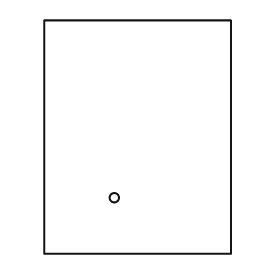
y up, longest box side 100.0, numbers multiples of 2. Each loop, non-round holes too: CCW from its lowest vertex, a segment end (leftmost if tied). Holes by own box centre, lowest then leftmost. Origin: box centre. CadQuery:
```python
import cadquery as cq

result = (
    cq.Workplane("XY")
    .moveTo(-40.0, -50.0)
    .lineTo(40.0, -50.0)
    .lineTo(40.0, 50.0)
    .lineTo(-40.0, 50.0)
    .close()
    .moveTo(-10.0, -26.0)
    .circle(2.0)
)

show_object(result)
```